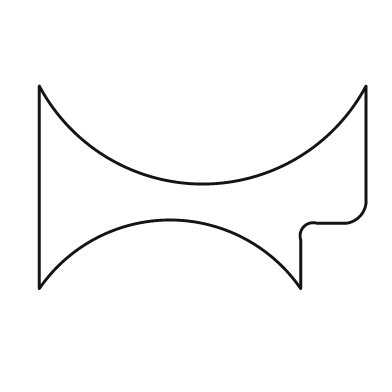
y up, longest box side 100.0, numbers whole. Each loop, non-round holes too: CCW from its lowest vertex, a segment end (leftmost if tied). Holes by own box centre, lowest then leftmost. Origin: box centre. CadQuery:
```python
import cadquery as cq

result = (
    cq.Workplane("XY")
    .moveTo(-50.0, -31.0)
    .threePointArc((-10.0, -10.0), (30.0, -31.0))
    .lineTo(30.0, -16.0)
    .threePointArc((31.0, -12.0), (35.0, -11.0))
    .lineTo(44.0, -11.0)
    .threePointArc((48.0, -9.0), (50.0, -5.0))
    .lineTo(50.0, 31.0)
    .threePointArc((0.0, 1.0), (-50.0, 31.0))
    .close()
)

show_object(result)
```